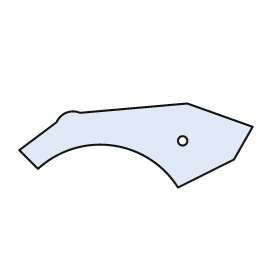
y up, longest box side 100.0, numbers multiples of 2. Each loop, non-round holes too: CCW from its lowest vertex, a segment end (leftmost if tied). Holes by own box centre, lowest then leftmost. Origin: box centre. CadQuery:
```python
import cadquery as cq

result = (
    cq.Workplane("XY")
    .moveTo(18.0, -18.0)
    .lineTo(42.0, -6.0)
    .lineTo(50.0, 8.0)
    .lineTo(22.0, 18.0)
    .lineTo(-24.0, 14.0)
    .threePointArc((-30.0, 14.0), (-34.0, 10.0))
    .lineTo(-50.0, -2.0)
    .lineTo(-42.0, -10.0)
    .threePointArc((-10.0, 0.0), (18.0, -18.0))
    .close()
    .moveTo(20.0, 2.0)
    .circle(2.0)
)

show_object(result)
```